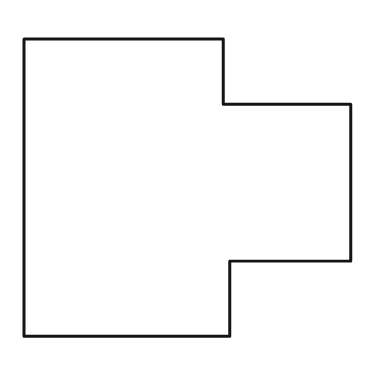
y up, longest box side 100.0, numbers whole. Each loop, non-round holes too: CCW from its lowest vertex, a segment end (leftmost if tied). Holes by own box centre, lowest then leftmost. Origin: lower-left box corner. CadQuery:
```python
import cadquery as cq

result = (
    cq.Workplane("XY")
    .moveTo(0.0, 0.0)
    .lineTo(63.0, 0.0)
    .lineTo(63.0, 23.0)
    .lineTo(100.0, 23.0)
    .lineTo(100.0, 71.0)
    .lineTo(61.0, 71.0)
    .lineTo(61.0, 91.0)
    .lineTo(0.0, 91.0)
    .close()
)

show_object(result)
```